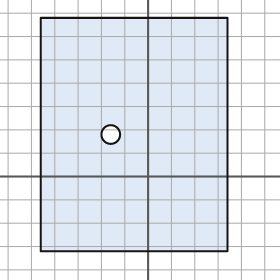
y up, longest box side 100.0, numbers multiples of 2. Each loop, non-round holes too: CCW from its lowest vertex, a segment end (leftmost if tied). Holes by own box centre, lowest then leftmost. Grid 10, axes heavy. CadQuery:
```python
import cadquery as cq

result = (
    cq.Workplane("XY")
    .moveTo(-46.0, -32.0)
    .lineTo(34.0, -32.0)
    .lineTo(34.0, 68.0)
    .lineTo(-46.0, 68.0)
    .close()
    .moveTo(-16.0, 18.0)
    .circle(4.0)
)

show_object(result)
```